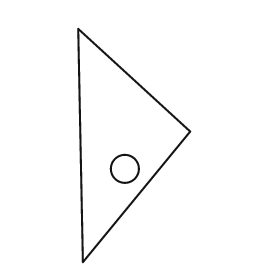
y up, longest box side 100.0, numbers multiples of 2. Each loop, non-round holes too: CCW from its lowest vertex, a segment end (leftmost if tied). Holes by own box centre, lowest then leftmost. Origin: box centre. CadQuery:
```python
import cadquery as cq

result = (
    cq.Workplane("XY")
    .moveTo(-22.0, -50.0)
    .lineTo(24.0, 6.0)
    .lineTo(-24.0, 50.0)
    .close()
    .moveTo(-4.0, -10.0)
    .circle(6.0)
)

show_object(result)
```